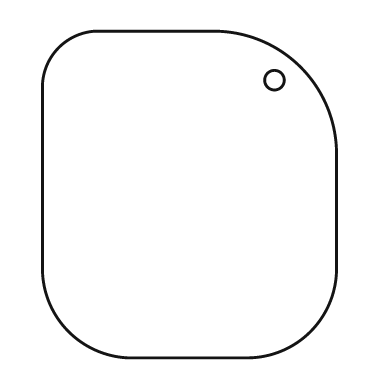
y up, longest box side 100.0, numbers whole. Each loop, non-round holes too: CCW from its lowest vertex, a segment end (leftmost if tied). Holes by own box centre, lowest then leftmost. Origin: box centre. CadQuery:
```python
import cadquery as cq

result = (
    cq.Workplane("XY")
    .moveTo(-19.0, -50.0)
    .lineTo(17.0, -50.0)
    .threePointArc((37.0, -42.0), (45.0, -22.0))
    .lineTo(45.0, 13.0)
    .threePointArc((34.0, 39.0), (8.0, 50.0))
    .lineTo(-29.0, 50.0)
    .threePointArc((-40.0, 45.0), (-45.0, 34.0))
    .lineTo(-45.0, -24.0)
    .threePointArc((-37.0, -42.0), (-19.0, -50.0))
    .close()
    .moveTo(26.0, 35.0)
    .circle(3.0)
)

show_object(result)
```